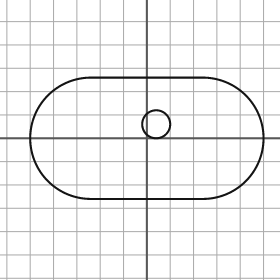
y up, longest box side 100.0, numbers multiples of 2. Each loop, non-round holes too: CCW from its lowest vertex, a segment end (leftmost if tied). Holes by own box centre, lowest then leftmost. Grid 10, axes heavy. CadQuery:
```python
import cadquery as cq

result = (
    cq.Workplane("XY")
    .moveTo(-24.0, -26.0)
    .lineTo(24.0, -26.0)
    .threePointArc((50.0, 0.0), (24.0, 26.0))
    .lineTo(-24.0, 26.0)
    .threePointArc((-50.0, 0.0), (-24.0, -26.0))
    .close()
    .moveTo(4.0, 6.0)
    .circle(6.0)
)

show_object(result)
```